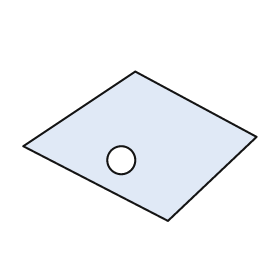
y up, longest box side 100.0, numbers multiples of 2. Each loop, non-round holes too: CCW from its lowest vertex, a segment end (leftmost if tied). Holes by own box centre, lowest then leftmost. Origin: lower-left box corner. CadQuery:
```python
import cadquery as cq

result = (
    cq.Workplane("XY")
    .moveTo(62.0, 0.0)
    .lineTo(100.0, 36.0)
    .lineTo(48.0, 64.0)
    .lineTo(0.0, 32.0)
    .close()
    .moveTo(42.0, 26.0)
    .circle(6.0)
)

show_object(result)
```